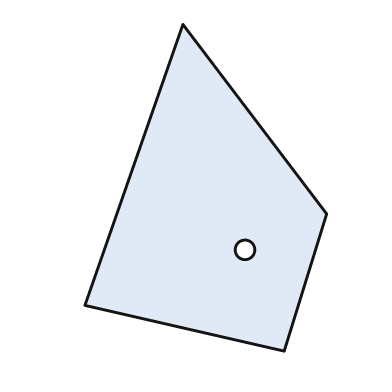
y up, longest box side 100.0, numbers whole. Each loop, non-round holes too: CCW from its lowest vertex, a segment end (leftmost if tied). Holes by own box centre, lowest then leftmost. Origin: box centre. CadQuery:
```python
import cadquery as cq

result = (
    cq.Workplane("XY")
    .moveTo(24.0, -50.0)
    .lineTo(37.0, -8.0)
    .lineTo(-7.0, 50.0)
    .lineTo(-37.0, -36.0)
    .close()
    .moveTo(12.0, -19.0)
    .circle(3.0)
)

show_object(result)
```